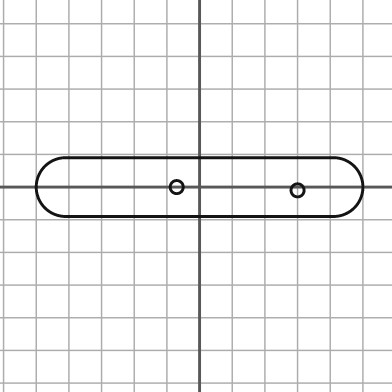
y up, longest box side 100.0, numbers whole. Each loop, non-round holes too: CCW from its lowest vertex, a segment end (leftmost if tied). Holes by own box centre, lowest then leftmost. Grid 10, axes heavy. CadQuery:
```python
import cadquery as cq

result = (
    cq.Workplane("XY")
    .moveTo(-41.0, -9.0)
    .lineTo(41.0, -9.0)
    .threePointArc((50.0, 0.0), (41.0, 9.0))
    .lineTo(-41.0, 9.0)
    .threePointArc((-50.0, 0.0), (-41.0, -9.0))
    .close()
    .moveTo(30.0, -1.0)
    .circle(2.0)
    .moveTo(-7.0, 0.0)
    .circle(2.0)
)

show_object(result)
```